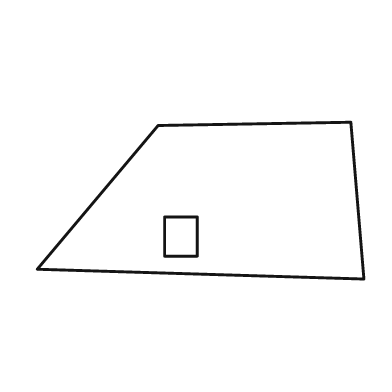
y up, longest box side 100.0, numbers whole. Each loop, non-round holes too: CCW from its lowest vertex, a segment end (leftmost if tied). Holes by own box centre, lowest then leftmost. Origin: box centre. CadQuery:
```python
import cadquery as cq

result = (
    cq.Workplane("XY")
    .moveTo(50.0, -24.0)
    .lineTo(46.0, 24.0)
    .lineTo(-13.0, 23.0)
    .lineTo(-50.0, -21.0)
    .close()
    .moveTo(-11.0, -17.0)
    .lineTo(-1.0, -17.0)
    .lineTo(-1.0, -5.0)
    .lineTo(-11.0, -5.0)
    .close()
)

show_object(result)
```